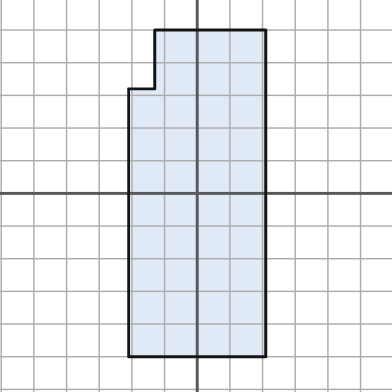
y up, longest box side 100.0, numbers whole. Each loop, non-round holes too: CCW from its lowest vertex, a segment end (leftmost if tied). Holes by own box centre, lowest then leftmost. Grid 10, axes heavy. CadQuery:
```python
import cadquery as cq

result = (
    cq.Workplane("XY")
    .moveTo(-21.0, -50.0)
    .lineTo(21.0, -50.0)
    .lineTo(21.0, 50.0)
    .lineTo(-13.0, 50.0)
    .lineTo(-13.0, 32.0)
    .lineTo(-21.0, 32.0)
    .close()
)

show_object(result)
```